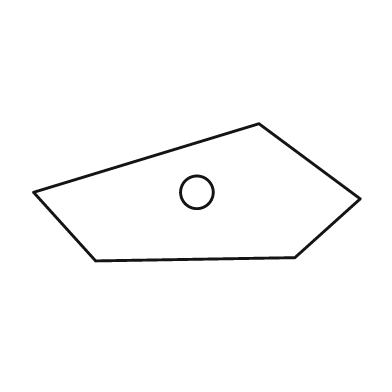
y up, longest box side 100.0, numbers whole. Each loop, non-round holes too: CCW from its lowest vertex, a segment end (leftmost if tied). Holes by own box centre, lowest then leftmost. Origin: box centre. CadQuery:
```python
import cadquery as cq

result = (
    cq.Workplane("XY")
    .moveTo(-31.0, -21.0)
    .lineTo(30.0, -20.0)
    .lineTo(50.0, -2.0)
    .lineTo(19.0, 21.0)
    .lineTo(-50.0, 0.0)
    .close()
    .moveTo(0.0, 0.0)
    .circle(5.0)
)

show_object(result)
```